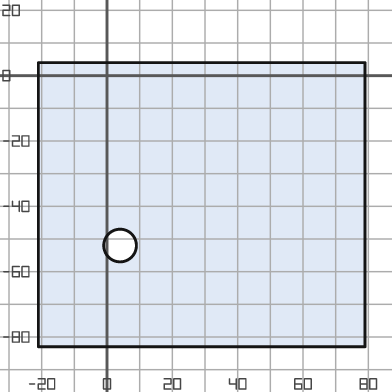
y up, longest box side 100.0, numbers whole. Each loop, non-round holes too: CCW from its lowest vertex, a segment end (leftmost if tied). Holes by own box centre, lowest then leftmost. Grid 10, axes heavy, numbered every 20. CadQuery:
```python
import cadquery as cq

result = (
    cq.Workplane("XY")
    .moveTo(-21.0, -83.0)
    .lineTo(79.0, -83.0)
    .lineTo(79.0, 4.0)
    .lineTo(-21.0, 4.0)
    .close()
    .moveTo(4.0, -52.0)
    .circle(5.0)
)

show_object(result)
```